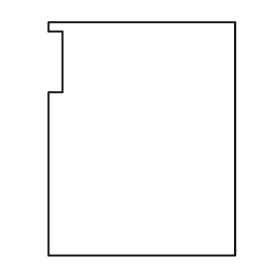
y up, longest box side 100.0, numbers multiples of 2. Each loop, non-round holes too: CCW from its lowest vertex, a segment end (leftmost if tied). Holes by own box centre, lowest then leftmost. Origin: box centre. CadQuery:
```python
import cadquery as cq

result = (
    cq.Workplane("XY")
    .moveTo(-40.0, -50.0)
    .lineTo(40.0, -50.0)
    .lineTo(40.0, 50.0)
    .lineTo(-40.0, 50.0)
    .lineTo(-40.0, 46.0)
    .lineTo(-34.0, 46.0)
    .lineTo(-34.0, 20.0)
    .lineTo(-40.0, 20.0)
    .close()
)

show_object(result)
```